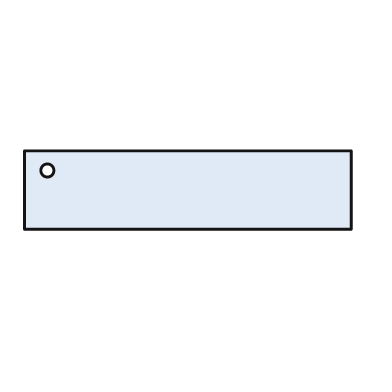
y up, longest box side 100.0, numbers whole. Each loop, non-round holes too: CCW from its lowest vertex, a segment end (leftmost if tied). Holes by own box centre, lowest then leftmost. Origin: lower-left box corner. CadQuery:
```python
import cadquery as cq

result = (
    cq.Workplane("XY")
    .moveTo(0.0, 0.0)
    .lineTo(100.0, 0.0)
    .lineTo(100.0, 24.0)
    .lineTo(0.0, 24.0)
    .close()
    .moveTo(7.0, 18.0)
    .circle(2.0)
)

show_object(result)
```